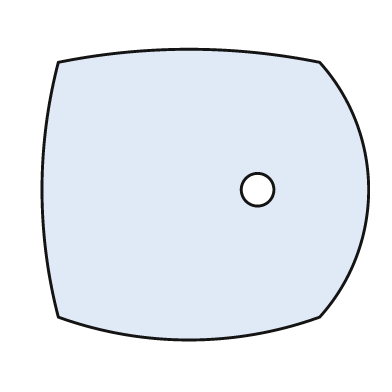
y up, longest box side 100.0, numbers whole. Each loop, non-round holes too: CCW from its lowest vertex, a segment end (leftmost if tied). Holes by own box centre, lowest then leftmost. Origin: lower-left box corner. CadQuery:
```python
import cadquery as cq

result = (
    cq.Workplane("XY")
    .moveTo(5.0, 7.0)
    .threePointArc((45.0, 0.0), (85.0, 7.0))
    .threePointArc((100.0, 46.0), (85.0, 85.0))
    .threePointArc((45.0, 89.0), (5.0, 85.0))
    .threePointArc((0.0, 46.0), (5.0, 7.0))
    .close()
    .moveTo(66.0, 46.0)
    .circle(5.0)
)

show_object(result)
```